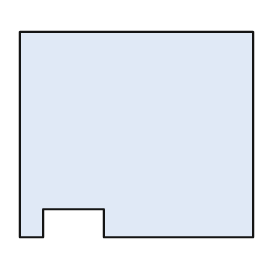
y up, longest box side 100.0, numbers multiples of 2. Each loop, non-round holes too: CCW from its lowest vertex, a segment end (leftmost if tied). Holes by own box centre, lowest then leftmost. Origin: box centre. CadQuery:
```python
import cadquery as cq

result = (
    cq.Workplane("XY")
    .moveTo(-50.0, -44.0)
    .lineTo(-40.0, -44.0)
    .lineTo(-40.0, -32.0)
    .lineTo(-14.0, -32.0)
    .lineTo(-14.0, -44.0)
    .lineTo(50.0, -44.0)
    .lineTo(50.0, 44.0)
    .lineTo(-50.0, 44.0)
    .close()
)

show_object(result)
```